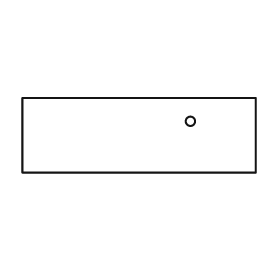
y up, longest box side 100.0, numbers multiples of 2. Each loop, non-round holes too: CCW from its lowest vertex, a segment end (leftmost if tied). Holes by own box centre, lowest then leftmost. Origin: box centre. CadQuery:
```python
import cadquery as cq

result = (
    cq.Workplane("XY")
    .moveTo(-50.0, -16.0)
    .lineTo(50.0, -16.0)
    .lineTo(50.0, 16.0)
    .lineTo(-50.0, 16.0)
    .close()
    .moveTo(22.0, 6.0)
    .circle(2.0)
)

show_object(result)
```